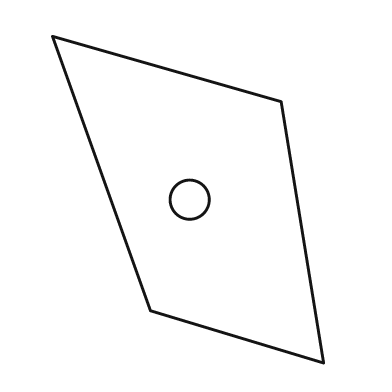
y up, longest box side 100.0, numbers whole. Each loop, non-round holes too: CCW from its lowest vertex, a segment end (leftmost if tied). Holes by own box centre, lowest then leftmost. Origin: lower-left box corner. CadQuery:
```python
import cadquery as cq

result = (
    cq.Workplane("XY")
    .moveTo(83.0, 0.0)
    .lineTo(70.0, 80.0)
    .lineTo(0.0, 100.0)
    .lineTo(30.0, 16.0)
    .close()
    .moveTo(42.0, 50.0)
    .circle(6.0)
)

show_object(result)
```